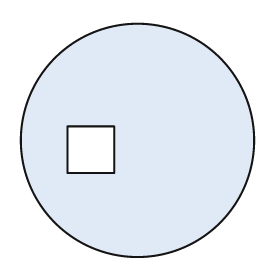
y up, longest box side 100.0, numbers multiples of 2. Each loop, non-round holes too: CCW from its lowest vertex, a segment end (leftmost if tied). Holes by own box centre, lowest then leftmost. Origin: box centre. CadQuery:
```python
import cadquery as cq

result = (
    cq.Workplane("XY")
    .moveTo(0.0, 0.0)
    .circle(50.0)
    .moveTo(-30.0, -14.0)
    .lineTo(-10.0, -14.0)
    .lineTo(-10.0, 6.0)
    .lineTo(-30.0, 6.0)
    .close()
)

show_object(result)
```